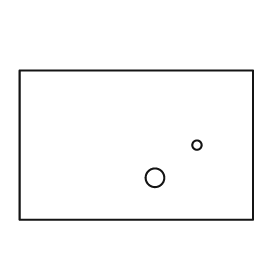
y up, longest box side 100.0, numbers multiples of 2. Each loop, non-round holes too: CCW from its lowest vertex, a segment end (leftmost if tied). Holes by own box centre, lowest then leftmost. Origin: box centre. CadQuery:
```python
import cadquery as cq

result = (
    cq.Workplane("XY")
    .moveTo(-50.0, -32.0)
    .lineTo(50.0, -32.0)
    .lineTo(50.0, 32.0)
    .lineTo(-50.0, 32.0)
    .close()
    .moveTo(8.0, -14.0)
    .circle(4.0)
    .moveTo(26.0, 0.0)
    .circle(2.0)
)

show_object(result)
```